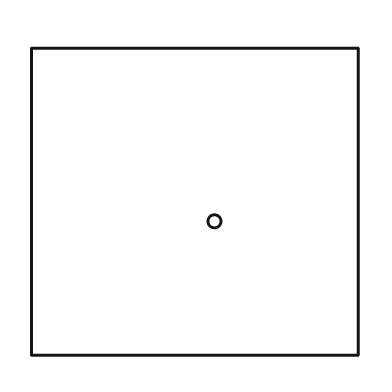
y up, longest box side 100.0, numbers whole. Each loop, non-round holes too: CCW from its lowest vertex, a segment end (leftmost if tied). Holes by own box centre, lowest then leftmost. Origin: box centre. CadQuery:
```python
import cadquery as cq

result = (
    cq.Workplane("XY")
    .moveTo(-50.0, -47.0)
    .lineTo(50.0, -47.0)
    .lineTo(50.0, 47.0)
    .lineTo(-50.0, 47.0)
    .close()
    .moveTo(6.0, -6.0)
    .circle(2.0)
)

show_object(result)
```